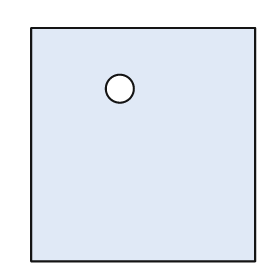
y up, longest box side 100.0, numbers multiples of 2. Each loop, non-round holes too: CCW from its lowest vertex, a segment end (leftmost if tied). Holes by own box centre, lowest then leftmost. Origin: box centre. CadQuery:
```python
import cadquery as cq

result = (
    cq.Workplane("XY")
    .moveTo(-48.0, -50.0)
    .lineTo(48.0, -50.0)
    .lineTo(48.0, 50.0)
    .lineTo(-48.0, 50.0)
    .close()
    .moveTo(-10.0, 24.0)
    .circle(6.0)
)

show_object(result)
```